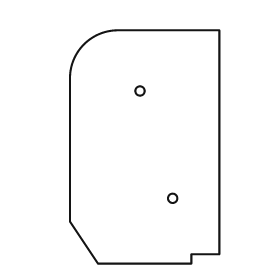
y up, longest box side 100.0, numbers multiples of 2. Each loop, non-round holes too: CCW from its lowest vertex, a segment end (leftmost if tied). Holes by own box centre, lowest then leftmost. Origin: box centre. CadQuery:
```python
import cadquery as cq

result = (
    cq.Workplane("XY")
    .moveTo(-20.0, -50.0)
    .lineTo(20.0, -50.0)
    .lineTo(20.0, -46.0)
    .lineTo(32.0, -46.0)
    .lineTo(32.0, 50.0)
    .lineTo(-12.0, 50.0)
    .threePointArc((-26.0, 44.0), (-32.0, 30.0))
    .lineTo(-32.0, -32.0)
    .close()
    .moveTo(12.0, -22.0)
    .circle(2.0)
    .moveTo(-2.0, 24.0)
    .circle(2.0)
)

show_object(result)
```